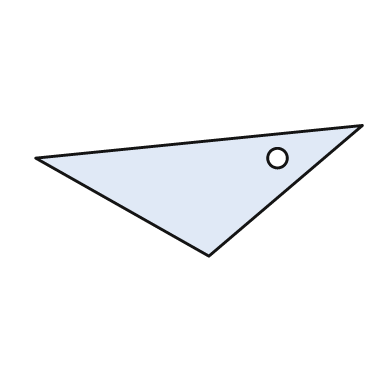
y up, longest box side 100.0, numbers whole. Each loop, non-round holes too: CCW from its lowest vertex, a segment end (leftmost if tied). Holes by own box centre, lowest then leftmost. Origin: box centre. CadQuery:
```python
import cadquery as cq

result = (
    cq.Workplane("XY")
    .moveTo(3.0, -20.0)
    .lineTo(50.0, 20.0)
    .lineTo(-50.0, 10.0)
    .close()
    .moveTo(24.0, 10.0)
    .circle(3.0)
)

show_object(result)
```